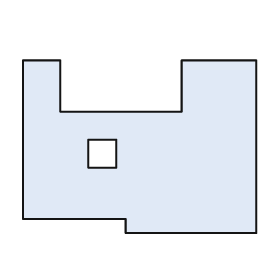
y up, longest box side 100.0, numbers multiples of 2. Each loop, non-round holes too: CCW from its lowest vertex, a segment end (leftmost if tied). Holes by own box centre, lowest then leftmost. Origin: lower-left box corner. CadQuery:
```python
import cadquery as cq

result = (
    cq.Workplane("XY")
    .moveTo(44.0, 0.0)
    .lineTo(100.0, 0.0)
    .lineTo(100.0, 74.0)
    .lineTo(68.0, 74.0)
    .lineTo(68.0, 52.0)
    .lineTo(16.0, 52.0)
    .lineTo(16.0, 74.0)
    .lineTo(0.0, 74.0)
    .lineTo(0.0, 6.0)
    .lineTo(44.0, 6.0)
    .close()
    .moveTo(28.0, 28.0)
    .lineTo(40.0, 28.0)
    .lineTo(40.0, 40.0)
    .lineTo(28.0, 40.0)
    .close()
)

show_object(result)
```